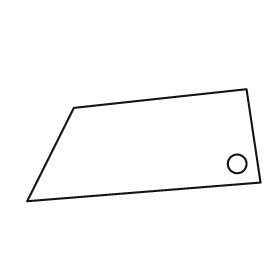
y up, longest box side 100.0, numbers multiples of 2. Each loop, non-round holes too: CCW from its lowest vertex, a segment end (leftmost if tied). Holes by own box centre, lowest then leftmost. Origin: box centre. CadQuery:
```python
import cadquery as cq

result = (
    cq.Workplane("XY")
    .moveTo(-50.0, -24.0)
    .lineTo(50.0, -16.0)
    .lineTo(44.0, 24.0)
    .lineTo(-30.0, 16.0)
    .close()
    .moveTo(40.0, -8.0)
    .circle(4.0)
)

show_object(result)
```